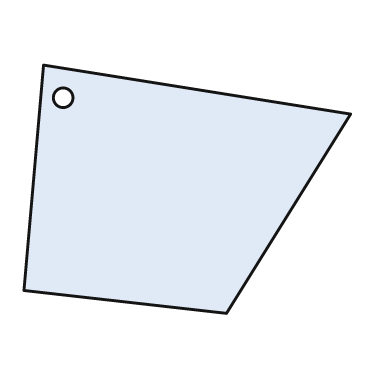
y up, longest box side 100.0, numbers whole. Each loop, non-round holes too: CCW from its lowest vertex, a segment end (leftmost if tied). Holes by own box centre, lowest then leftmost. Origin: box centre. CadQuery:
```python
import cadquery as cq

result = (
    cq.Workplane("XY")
    .moveTo(12.0, -38.0)
    .lineTo(50.0, 23.0)
    .lineTo(-44.0, 38.0)
    .lineTo(-50.0, -31.0)
    .close()
    .moveTo(-38.0, 28.0)
    .circle(3.0)
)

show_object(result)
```